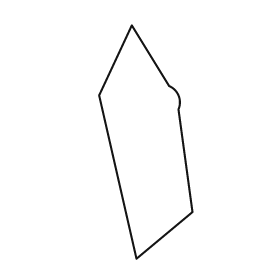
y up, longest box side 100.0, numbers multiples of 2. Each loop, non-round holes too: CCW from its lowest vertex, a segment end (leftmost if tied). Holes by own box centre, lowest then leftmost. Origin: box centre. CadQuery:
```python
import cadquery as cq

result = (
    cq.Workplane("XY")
    .moveTo(-4.0, -50.0)
    .lineTo(20.0, -30.0)
    .lineTo(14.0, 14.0)
    .threePointArc((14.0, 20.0), (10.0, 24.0))
    .lineTo(-6.0, 50.0)
    .lineTo(-20.0, 20.0)
    .close()
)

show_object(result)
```